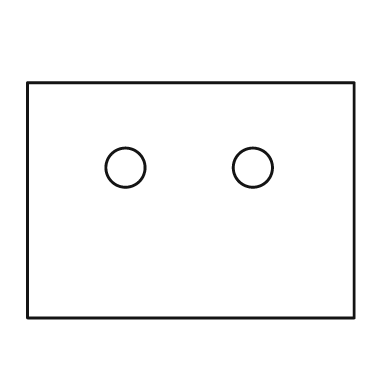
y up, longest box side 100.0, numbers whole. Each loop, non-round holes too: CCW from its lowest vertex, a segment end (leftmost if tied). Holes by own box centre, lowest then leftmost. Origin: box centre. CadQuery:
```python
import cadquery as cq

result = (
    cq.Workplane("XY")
    .moveTo(-50.0, -36.0)
    .lineTo(50.0, -36.0)
    .lineTo(50.0, 36.0)
    .lineTo(-50.0, 36.0)
    .close()
    .moveTo(-20.0, 10.0)
    .circle(6.0)
    .moveTo(19.0, 10.0)
    .circle(6.0)
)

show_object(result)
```